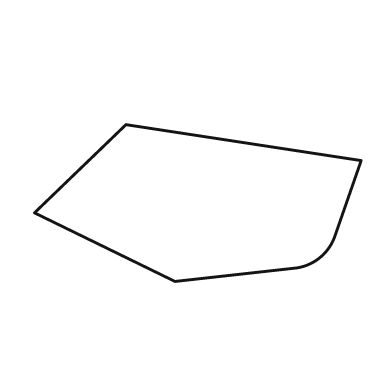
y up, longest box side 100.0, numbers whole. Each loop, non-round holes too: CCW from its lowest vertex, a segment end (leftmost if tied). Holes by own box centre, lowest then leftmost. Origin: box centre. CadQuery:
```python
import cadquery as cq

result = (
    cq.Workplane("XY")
    .moveTo(-7.0, -24.0)
    .lineTo(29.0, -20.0)
    .threePointArc((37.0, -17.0), (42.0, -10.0))
    .lineTo(50.0, 13.0)
    .lineTo(-22.0, 24.0)
    .lineTo(-50.0, -3.0)
    .close()
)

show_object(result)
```